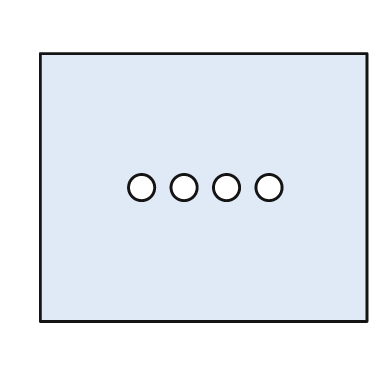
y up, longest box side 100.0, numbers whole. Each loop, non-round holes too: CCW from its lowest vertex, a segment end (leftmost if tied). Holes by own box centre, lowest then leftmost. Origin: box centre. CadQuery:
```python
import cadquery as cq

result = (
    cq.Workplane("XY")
    .moveTo(-50.0, -41.0)
    .lineTo(50.0, -41.0)
    .lineTo(50.0, 41.0)
    .lineTo(-50.0, 41.0)
    .close()
    .moveTo(-19.0, 0.0)
    .circle(4.0)
    .moveTo(-6.0, 0.0)
    .circle(4.0)
    .moveTo(7.0, 0.0)
    .circle(4.0)
    .moveTo(20.0, 0.0)
    .circle(4.0)
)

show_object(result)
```